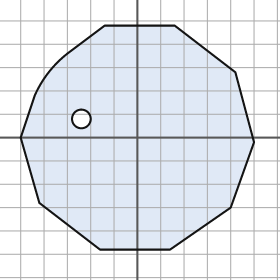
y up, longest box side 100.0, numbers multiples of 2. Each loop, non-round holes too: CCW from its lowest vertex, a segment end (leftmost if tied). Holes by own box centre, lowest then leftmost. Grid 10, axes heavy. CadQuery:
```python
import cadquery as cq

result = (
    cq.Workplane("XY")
    .moveTo(-16.0, -48.0)
    .lineTo(14.0, -48.0)
    .lineTo(40.0, -30.0)
    .lineTo(50.0, -2.0)
    .lineTo(42.0, 28.0)
    .lineTo(16.0, 48.0)
    .lineTo(-14.0, 48.0)
    .lineTo(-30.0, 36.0)
    .threePointArc((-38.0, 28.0), (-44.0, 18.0))
    .lineTo(-50.0, 0.0)
    .lineTo(-42.0, -28.0)
    .close()
    .moveTo(-24.0, 8.0)
    .circle(4.0)
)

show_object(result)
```